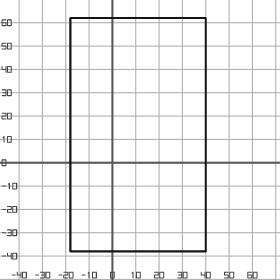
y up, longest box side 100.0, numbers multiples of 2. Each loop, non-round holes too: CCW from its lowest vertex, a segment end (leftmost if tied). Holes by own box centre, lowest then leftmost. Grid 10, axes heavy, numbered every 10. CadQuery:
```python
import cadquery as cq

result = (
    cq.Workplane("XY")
    .moveTo(-18.0, -38.0)
    .lineTo(40.0, -38.0)
    .lineTo(40.0, 62.0)
    .lineTo(-18.0, 62.0)
    .close()
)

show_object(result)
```